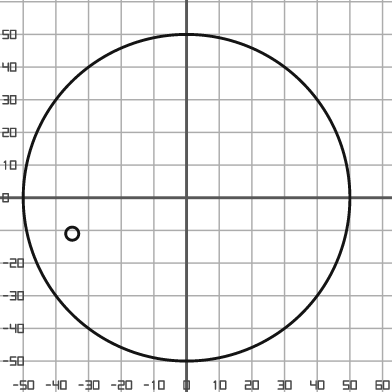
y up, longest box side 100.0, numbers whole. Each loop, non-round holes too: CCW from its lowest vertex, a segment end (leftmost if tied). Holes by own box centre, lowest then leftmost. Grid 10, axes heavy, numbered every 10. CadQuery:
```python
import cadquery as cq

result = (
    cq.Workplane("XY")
    .moveTo(0.0, 0.0)
    .circle(50.0)
    .moveTo(-35.0, -11.0)
    .circle(2.0)
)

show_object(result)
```